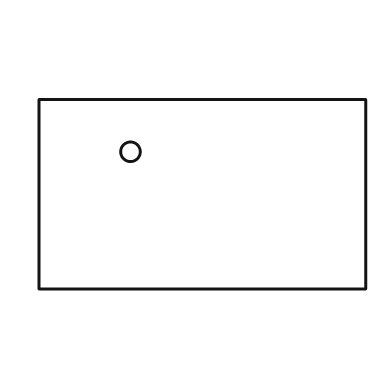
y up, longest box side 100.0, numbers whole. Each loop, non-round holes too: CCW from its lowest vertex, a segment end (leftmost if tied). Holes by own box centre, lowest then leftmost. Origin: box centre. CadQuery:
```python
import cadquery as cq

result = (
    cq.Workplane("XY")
    .moveTo(-50.0, -29.0)
    .lineTo(50.0, -29.0)
    .lineTo(50.0, 29.0)
    .lineTo(-50.0, 29.0)
    .close()
    .moveTo(-22.0, 13.0)
    .circle(3.0)
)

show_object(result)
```